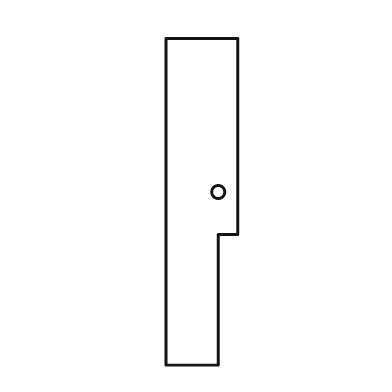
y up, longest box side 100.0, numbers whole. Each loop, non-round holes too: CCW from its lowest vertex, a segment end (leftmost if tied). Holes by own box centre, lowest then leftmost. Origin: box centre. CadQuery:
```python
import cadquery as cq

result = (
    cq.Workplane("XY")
    .moveTo(-11.0, -50.0)
    .lineTo(5.0, -50.0)
    .lineTo(5.0, -10.0)
    .lineTo(11.0, -10.0)
    .lineTo(11.0, 50.0)
    .lineTo(-11.0, 50.0)
    .close()
    .moveTo(5.0, 3.0)
    .circle(2.0)
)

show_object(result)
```